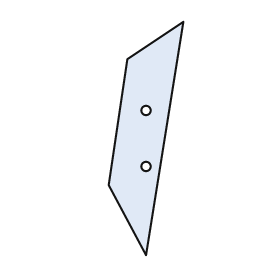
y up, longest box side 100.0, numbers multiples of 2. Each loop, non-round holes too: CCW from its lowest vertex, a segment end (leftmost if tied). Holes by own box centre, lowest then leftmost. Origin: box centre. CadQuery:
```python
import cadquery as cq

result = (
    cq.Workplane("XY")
    .moveTo(0.0, -50.0)
    .lineTo(16.0, 50.0)
    .lineTo(-8.0, 34.0)
    .lineTo(-16.0, -20.0)
    .close()
    .moveTo(0.0, -12.0)
    .circle(2.0)
    .moveTo(0.0, 12.0)
    .circle(2.0)
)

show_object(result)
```